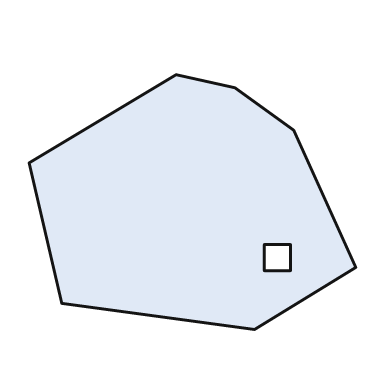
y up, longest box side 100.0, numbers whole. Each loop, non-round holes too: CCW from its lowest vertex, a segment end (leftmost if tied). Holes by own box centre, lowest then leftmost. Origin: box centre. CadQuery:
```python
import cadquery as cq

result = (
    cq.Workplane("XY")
    .moveTo(19.0, -39.0)
    .lineTo(50.0, -20.0)
    .lineTo(31.0, 22.0)
    .lineTo(13.0, 35.0)
    .lineTo(-5.0, 39.0)
    .lineTo(-50.0, 12.0)
    .lineTo(-40.0, -31.0)
    .close()
    .moveTo(22.0, -21.0)
    .lineTo(30.0, -21.0)
    .lineTo(30.0, -13.0)
    .lineTo(22.0, -13.0)
    .close()
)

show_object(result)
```